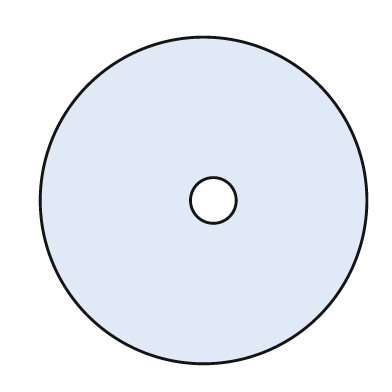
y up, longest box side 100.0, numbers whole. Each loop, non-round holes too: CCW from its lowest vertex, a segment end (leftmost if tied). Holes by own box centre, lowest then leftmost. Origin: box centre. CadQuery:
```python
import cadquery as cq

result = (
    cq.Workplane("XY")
    .moveTo(0.0, 0.0)
    .circle(50.0)
    .moveTo(3.0, 0.0)
    .circle(7.0)
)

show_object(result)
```